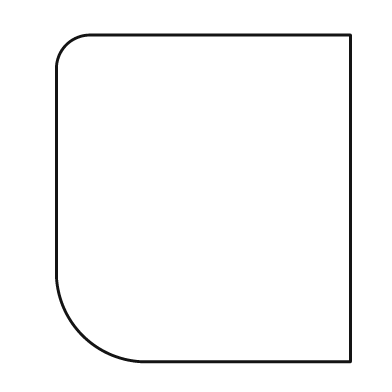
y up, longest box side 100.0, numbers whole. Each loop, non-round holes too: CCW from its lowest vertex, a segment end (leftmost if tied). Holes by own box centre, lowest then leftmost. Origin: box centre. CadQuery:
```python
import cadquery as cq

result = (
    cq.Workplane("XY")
    .moveTo(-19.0, -50.0)
    .lineTo(45.0, -50.0)
    .lineTo(45.0, 50.0)
    .lineTo(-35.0, 50.0)
    .threePointArc((-42.0, 47.0), (-45.0, 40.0))
    .lineTo(-45.0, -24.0)
    .threePointArc((-37.0, -42.0), (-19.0, -50.0))
    .close()
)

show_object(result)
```